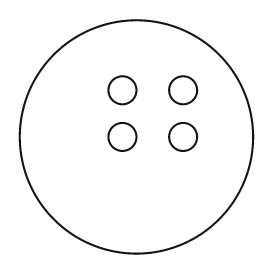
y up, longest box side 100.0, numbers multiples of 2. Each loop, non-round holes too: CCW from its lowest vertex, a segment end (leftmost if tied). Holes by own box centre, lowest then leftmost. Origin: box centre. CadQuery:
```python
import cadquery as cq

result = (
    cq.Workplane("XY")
    .moveTo(0.0, 0.0)
    .circle(50.0)
    .moveTo(-6.0, 0.0)
    .circle(6.0)
    .moveTo(20.0, 0.0)
    .circle(6.0)
    .moveTo(-6.0, 20.0)
    .circle(6.0)
    .moveTo(20.0, 20.0)
    .circle(6.0)
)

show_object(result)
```